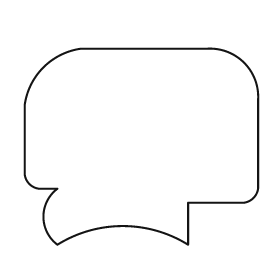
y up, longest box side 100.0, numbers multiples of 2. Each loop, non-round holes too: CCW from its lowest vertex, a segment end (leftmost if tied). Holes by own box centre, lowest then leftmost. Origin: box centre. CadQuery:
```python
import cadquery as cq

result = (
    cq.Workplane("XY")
    .moveTo(-36.0, -42.0)
    .threePointArc((-8.0, -34.0), (20.0, -42.0))
    .lineTo(20.0, -24.0)
    .lineTo(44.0, -24.0)
    .threePointArc((48.0, -22.0), (50.0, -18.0))
    .lineTo(50.0, 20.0)
    .threePointArc((44.0, 36.0), (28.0, 42.0))
    .lineTo(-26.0, 42.0)
    .threePointArc((-42.0, 34.0), (-50.0, 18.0))
    .lineTo(-50.0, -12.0)
    .threePointArc((-48.0, -16.0), (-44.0, -18.0))
    .lineTo(-36.0, -18.0)
    .threePointArc((-42.0, -30.0), (-36.0, -42.0))
    .close()
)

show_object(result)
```